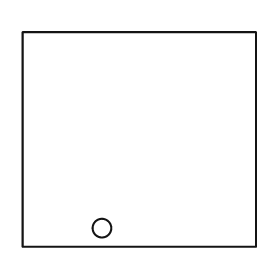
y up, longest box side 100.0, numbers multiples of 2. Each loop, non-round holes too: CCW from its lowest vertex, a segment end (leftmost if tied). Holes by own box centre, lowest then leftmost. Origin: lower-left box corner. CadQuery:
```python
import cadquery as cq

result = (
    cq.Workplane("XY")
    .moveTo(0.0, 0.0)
    .lineTo(100.0, 0.0)
    .lineTo(100.0, 92.0)
    .lineTo(0.0, 92.0)
    .close()
    .moveTo(34.0, 8.0)
    .circle(4.0)
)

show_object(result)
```